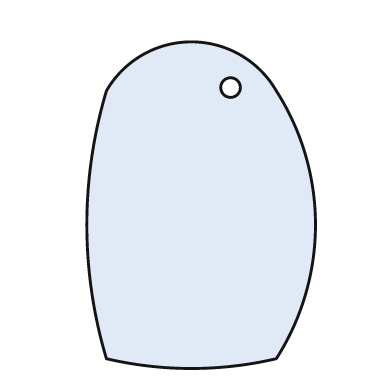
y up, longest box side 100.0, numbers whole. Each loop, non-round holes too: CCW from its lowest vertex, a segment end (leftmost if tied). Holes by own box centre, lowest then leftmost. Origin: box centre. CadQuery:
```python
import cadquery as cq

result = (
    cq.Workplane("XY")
    .moveTo(-29.0, -47.0)
    .threePointArc((-3.0, -50.0), (23.0, -47.0))
    .threePointArc((35.0, -6.0), (23.0, 35.0))
    .threePointArc((-3.0, 50.0), (-29.0, 35.0))
    .threePointArc((-35.0, -6.0), (-29.0, -47.0))
    .close()
    .moveTo(9.0, 36.0)
    .circle(3.0)
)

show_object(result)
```